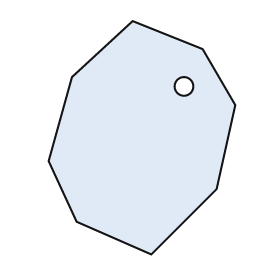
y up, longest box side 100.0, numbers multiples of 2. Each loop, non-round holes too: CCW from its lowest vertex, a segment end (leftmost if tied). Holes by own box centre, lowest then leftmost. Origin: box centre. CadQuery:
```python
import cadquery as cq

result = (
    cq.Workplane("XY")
    .moveTo(4.0, -50.0)
    .lineTo(32.0, -22.0)
    .lineTo(40.0, 14.0)
    .lineTo(26.0, 38.0)
    .lineTo(-4.0, 50.0)
    .lineTo(-30.0, 26.0)
    .lineTo(-40.0, -10.0)
    .lineTo(-28.0, -36.0)
    .close()
    .moveTo(18.0, 22.0)
    .circle(4.0)
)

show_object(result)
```